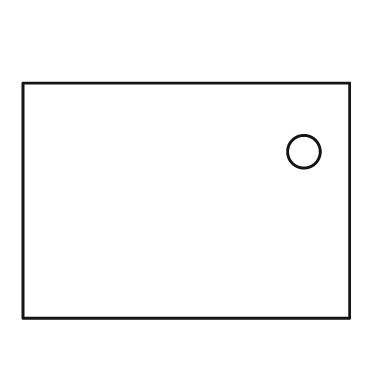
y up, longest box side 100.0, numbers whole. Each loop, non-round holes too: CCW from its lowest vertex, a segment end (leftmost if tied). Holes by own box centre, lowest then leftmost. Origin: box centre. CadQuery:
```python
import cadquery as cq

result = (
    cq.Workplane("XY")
    .moveTo(-50.0, -36.0)
    .lineTo(50.0, -36.0)
    .lineTo(50.0, 36.0)
    .lineTo(-50.0, 36.0)
    .close()
    .moveTo(36.0, 15.0)
    .circle(5.0)
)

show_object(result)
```